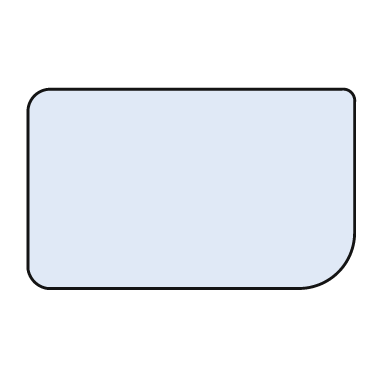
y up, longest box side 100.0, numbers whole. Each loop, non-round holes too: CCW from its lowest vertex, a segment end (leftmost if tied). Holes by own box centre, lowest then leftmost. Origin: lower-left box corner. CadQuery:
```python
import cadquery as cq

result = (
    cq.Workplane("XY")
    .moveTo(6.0, 0.0)
    .lineTo(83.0, 0.0)
    .threePointArc((95.0, 5.0), (100.0, 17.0))
    .lineTo(100.0, 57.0)
    .threePointArc((99.0, 60.0), (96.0, 61.0))
    .lineTo(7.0, 61.0)
    .threePointArc((2.0, 59.0), (0.0, 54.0))
    .lineTo(0.0, 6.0)
    .threePointArc((2.0, 2.0), (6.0, 0.0))
    .close()
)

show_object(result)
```